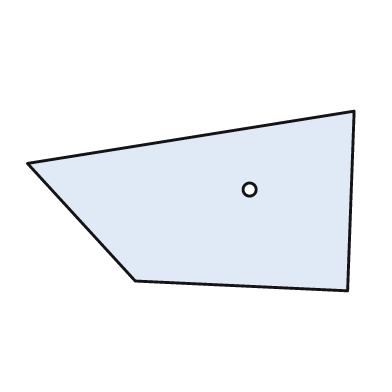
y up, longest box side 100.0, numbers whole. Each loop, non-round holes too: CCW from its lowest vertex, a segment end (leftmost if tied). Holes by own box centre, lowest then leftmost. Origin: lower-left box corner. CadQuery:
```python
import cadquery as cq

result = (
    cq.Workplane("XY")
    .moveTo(98.0, 0.0)
    .lineTo(100.0, 55.0)
    .lineTo(0.0, 39.0)
    .lineTo(33.0, 3.0)
    .close()
    .moveTo(68.0, 31.0)
    .circle(2.0)
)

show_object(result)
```